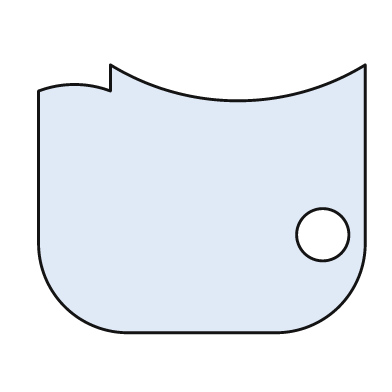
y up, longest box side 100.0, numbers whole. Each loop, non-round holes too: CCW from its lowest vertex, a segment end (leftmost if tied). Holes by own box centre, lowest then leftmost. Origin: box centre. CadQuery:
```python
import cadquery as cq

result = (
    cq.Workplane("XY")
    .moveTo(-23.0, -41.0)
    .lineTo(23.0, -41.0)
    .threePointArc((42.0, -33.0), (50.0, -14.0))
    .lineTo(50.0, 41.0)
    .threePointArc((11.0, 30.0), (-28.0, 41.0))
    .lineTo(-28.0, 33.0)
    .threePointArc((-39.0, 35.0), (-50.0, 33.0))
    .lineTo(-50.0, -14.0)
    .threePointArc((-42.0, -33.0), (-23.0, -41.0))
    .close()
    .moveTo(37.0, -11.0)
    .circle(8.0)
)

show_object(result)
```